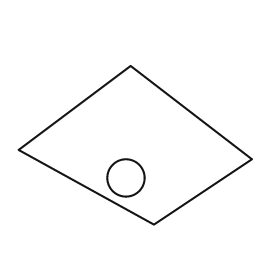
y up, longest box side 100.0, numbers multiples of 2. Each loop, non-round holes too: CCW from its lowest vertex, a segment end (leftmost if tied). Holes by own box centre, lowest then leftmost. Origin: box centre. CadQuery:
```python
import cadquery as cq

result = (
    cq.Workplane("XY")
    .moveTo(8.0, -34.0)
    .lineTo(50.0, -6.0)
    .lineTo(-2.0, 34.0)
    .lineTo(-50.0, -2.0)
    .close()
    .moveTo(-4.0, -14.0)
    .circle(8.0)
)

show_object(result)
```